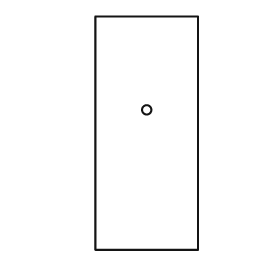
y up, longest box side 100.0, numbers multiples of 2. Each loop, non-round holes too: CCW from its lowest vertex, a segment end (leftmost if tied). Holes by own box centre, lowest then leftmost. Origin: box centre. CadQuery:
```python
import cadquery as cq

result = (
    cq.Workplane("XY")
    .moveTo(-22.0, -50.0)
    .lineTo(22.0, -50.0)
    .lineTo(22.0, 50.0)
    .lineTo(-22.0, 50.0)
    .close()
    .moveTo(0.0, 10.0)
    .circle(2.0)
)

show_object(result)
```